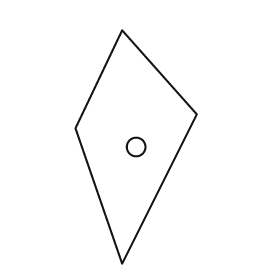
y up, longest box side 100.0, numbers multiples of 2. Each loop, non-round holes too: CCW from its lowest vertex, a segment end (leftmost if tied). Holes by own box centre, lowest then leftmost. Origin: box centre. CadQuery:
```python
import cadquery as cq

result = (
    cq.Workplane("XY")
    .moveTo(-6.0, -50.0)
    .lineTo(26.0, 14.0)
    .lineTo(-6.0, 50.0)
    .lineTo(-26.0, 8.0)
    .close()
    .moveTo(0.0, 0.0)
    .circle(4.0)
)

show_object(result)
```